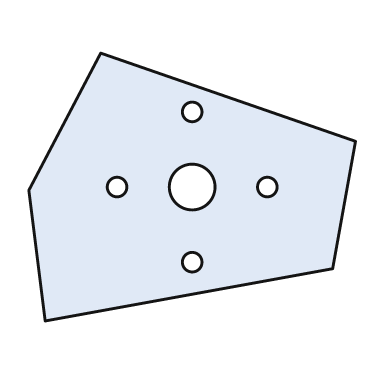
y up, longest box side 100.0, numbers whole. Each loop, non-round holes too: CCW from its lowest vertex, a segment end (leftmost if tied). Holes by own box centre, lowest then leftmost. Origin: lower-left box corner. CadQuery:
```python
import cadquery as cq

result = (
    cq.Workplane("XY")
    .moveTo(5.0, 0.0)
    .lineTo(93.0, 16.0)
    .lineTo(100.0, 55.0)
    .lineTo(22.0, 82.0)
    .lineTo(0.0, 40.0)
    .close()
    .moveTo(50.0, 18.0)
    .circle(3.0)
    .moveTo(27.0, 41.0)
    .circle(3.0)
    .moveTo(50.0, 41.0)
    .circle(7.0)
    .moveTo(73.0, 41.0)
    .circle(3.0)
    .moveTo(50.0, 64.0)
    .circle(3.0)
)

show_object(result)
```